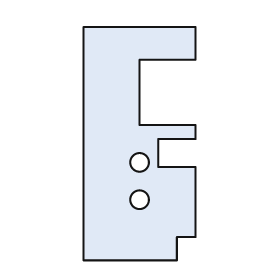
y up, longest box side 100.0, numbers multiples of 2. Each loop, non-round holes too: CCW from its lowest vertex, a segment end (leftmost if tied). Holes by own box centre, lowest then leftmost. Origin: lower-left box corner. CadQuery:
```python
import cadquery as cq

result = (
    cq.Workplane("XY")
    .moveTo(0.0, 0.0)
    .lineTo(40.0, 0.0)
    .lineTo(40.0, 10.0)
    .lineTo(48.0, 10.0)
    .lineTo(48.0, 40.0)
    .lineTo(32.0, 40.0)
    .lineTo(32.0, 52.0)
    .lineTo(48.0, 52.0)
    .lineTo(48.0, 58.0)
    .lineTo(24.0, 58.0)
    .lineTo(24.0, 86.0)
    .lineTo(48.0, 86.0)
    .lineTo(48.0, 100.0)
    .lineTo(0.0, 100.0)
    .close()
    .moveTo(24.0, 26.0)
    .circle(4.0)
    .moveTo(24.0, 42.0)
    .circle(4.0)
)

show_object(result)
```